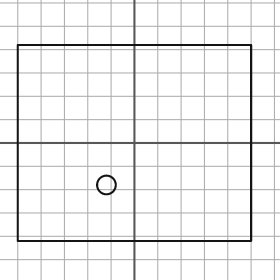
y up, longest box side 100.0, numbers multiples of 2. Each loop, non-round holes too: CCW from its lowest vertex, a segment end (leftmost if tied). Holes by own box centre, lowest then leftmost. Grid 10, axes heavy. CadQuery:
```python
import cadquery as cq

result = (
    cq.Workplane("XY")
    .moveTo(-50.0, -42.0)
    .lineTo(50.0, -42.0)
    .lineTo(50.0, 42.0)
    .lineTo(-50.0, 42.0)
    .close()
    .moveTo(-12.0, -18.0)
    .circle(4.0)
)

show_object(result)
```